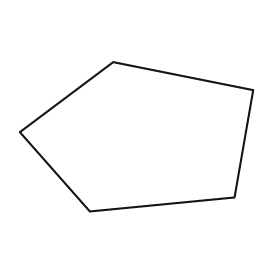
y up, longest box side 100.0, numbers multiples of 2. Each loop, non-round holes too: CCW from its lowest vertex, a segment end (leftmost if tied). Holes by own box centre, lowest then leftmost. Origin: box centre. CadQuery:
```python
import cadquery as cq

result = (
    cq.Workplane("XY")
    .moveTo(-20.0, -32.0)
    .lineTo(42.0, -26.0)
    .lineTo(50.0, 20.0)
    .lineTo(-10.0, 32.0)
    .lineTo(-50.0, 2.0)
    .close()
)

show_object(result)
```